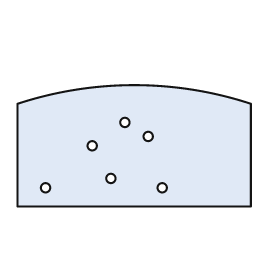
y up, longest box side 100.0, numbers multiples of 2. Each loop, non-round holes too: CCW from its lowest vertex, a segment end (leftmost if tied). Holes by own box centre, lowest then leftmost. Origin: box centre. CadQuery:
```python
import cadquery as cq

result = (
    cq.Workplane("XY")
    .moveTo(-50.0, -26.0)
    .lineTo(50.0, -26.0)
    .lineTo(50.0, 18.0)
    .threePointArc((0.0, 26.0), (-50.0, 18.0))
    .close()
    .moveTo(-38.0, -18.0)
    .circle(2.0)
    .moveTo(12.0, -18.0)
    .circle(2.0)
    .moveTo(-10.0, -14.0)
    .circle(2.0)
    .moveTo(-18.0, 0.0)
    .circle(2.0)
    .moveTo(6.0, 4.0)
    .circle(2.0)
    .moveTo(-4.0, 10.0)
    .circle(2.0)
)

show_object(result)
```